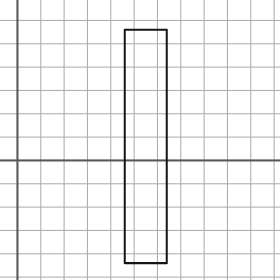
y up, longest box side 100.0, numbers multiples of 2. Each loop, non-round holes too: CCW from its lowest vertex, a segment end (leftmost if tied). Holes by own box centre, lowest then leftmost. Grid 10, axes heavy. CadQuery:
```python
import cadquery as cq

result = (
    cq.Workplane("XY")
    .moveTo(46.0, -44.0)
    .lineTo(64.0, -44.0)
    .lineTo(64.0, 56.0)
    .lineTo(46.0, 56.0)
    .close()
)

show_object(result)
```